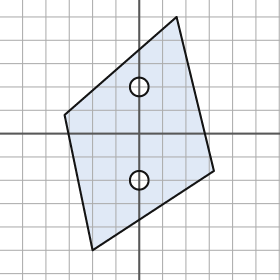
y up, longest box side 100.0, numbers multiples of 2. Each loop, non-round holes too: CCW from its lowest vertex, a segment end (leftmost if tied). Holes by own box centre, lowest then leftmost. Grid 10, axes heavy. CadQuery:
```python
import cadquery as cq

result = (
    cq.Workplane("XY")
    .moveTo(-20.0, -50.0)
    .lineTo(32.0, -16.0)
    .lineTo(16.0, 50.0)
    .lineTo(-32.0, 8.0)
    .close()
    .moveTo(0.0, -20.0)
    .circle(4.0)
    .moveTo(0.0, 20.0)
    .circle(4.0)
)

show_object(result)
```